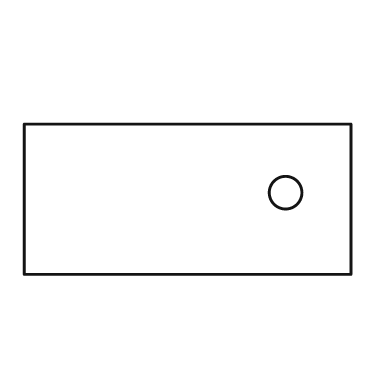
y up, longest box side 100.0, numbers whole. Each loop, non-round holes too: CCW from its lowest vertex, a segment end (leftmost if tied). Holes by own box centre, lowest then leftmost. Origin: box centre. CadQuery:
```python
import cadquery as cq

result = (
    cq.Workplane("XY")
    .moveTo(-50.0, -23.0)
    .lineTo(50.0, -23.0)
    .lineTo(50.0, 23.0)
    .lineTo(-50.0, 23.0)
    .close()
    .moveTo(30.0, 2.0)
    .circle(5.0)
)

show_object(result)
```